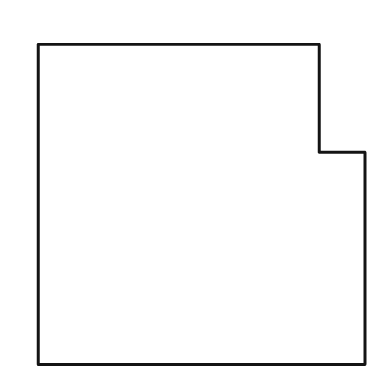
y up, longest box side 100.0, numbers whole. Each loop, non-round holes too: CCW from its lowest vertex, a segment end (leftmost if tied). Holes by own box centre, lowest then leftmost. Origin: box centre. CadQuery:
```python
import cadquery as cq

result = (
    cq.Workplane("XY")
    .moveTo(-50.0, -49.0)
    .lineTo(50.0, -49.0)
    .lineTo(50.0, 16.0)
    .lineTo(36.0, 16.0)
    .lineTo(36.0, 49.0)
    .lineTo(-50.0, 49.0)
    .close()
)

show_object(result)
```